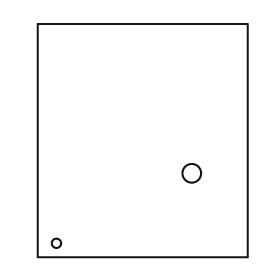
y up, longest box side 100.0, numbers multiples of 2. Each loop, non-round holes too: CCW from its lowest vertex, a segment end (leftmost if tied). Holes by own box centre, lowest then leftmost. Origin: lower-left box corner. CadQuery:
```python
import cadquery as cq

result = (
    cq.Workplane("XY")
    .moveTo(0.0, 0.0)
    .lineTo(90.0, 0.0)
    .lineTo(90.0, 100.0)
    .lineTo(0.0, 100.0)
    .close()
    .moveTo(8.0, 6.0)
    .circle(2.0)
    .moveTo(66.0, 36.0)
    .circle(4.0)
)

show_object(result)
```